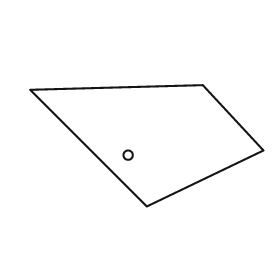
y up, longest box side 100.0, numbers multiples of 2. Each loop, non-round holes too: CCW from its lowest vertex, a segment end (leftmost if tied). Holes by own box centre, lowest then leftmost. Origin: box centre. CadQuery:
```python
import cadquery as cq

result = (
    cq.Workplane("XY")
    .moveTo(0.0, -26.0)
    .lineTo(50.0, -2.0)
    .lineTo(24.0, 26.0)
    .lineTo(-50.0, 24.0)
    .close()
    .moveTo(-8.0, -4.0)
    .circle(2.0)
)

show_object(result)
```